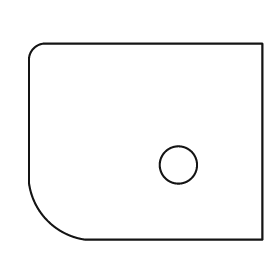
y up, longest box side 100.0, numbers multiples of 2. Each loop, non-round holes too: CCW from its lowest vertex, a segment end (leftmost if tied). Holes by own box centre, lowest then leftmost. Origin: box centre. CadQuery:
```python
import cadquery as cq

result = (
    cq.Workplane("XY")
    .moveTo(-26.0, -42.0)
    .lineTo(50.0, -42.0)
    .lineTo(50.0, 42.0)
    .lineTo(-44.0, 42.0)
    .threePointArc((-48.0, 40.0), (-50.0, 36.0))
    .lineTo(-50.0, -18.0)
    .threePointArc((-42.0, -34.0), (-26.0, -42.0))
    .close()
    .moveTo(14.0, -10.0)
    .circle(8.0)
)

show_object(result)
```